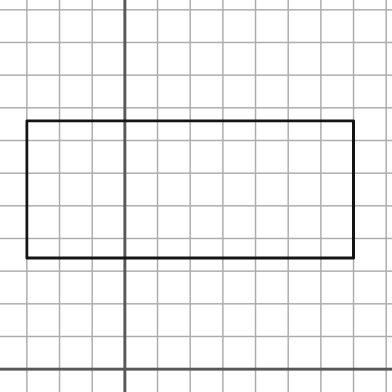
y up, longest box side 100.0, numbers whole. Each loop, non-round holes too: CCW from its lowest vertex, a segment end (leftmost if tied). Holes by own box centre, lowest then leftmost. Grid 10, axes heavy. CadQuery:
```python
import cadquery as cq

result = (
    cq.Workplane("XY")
    .moveTo(-30.0, 34.0)
    .lineTo(70.0, 34.0)
    .lineTo(70.0, 76.0)
    .lineTo(-30.0, 76.0)
    .close()
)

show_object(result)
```